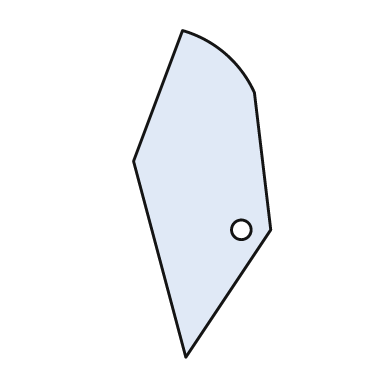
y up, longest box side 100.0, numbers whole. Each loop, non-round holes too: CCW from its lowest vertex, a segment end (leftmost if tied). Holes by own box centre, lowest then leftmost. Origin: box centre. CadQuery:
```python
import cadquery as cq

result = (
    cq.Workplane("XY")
    .moveTo(-5.0, -50.0)
    .lineTo(21.0, -11.0)
    .lineTo(16.0, 31.0)
    .threePointArc((7.0, 43.0), (-6.0, 50.0))
    .lineTo(-21.0, 10.0)
    .close()
    .moveTo(12.0, -11.0)
    .circle(3.0)
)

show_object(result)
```